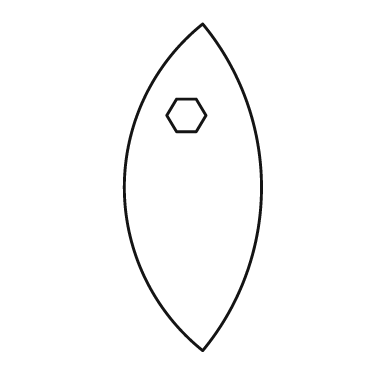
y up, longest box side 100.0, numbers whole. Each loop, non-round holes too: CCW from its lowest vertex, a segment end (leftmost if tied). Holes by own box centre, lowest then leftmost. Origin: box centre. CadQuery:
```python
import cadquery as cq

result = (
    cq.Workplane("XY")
    .moveTo(3.0, -50.0)
    .threePointArc((21.0, 0.0), (3.0, 50.0))
    .threePointArc((-21.0, 0.0), (3.0, -50.0))
    .close()
    .moveTo(-5.0, 17.0)
    .lineTo(1.0, 17.0)
    .lineTo(4.0, 22.0)
    .lineTo(1.0, 27.0)
    .lineTo(-5.0, 27.0)
    .lineTo(-8.0, 22.0)
    .close()
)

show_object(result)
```